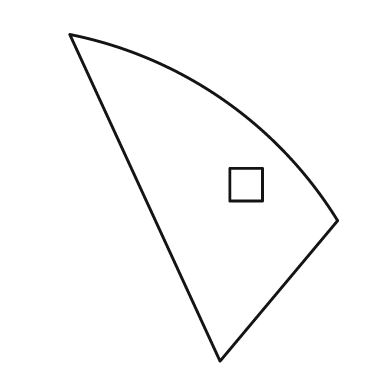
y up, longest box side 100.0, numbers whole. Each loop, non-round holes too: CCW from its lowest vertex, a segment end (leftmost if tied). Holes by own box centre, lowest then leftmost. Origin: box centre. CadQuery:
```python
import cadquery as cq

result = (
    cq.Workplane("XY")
    .moveTo(5.0, -50.0)
    .lineTo(41.0, -7.0)
    .threePointArc((6.0, 30.0), (-41.0, 50.0))
    .close()
    .moveTo(8.0, -1.0)
    .lineTo(18.0, -1.0)
    .lineTo(18.0, 9.0)
    .lineTo(8.0, 9.0)
    .close()
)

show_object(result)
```